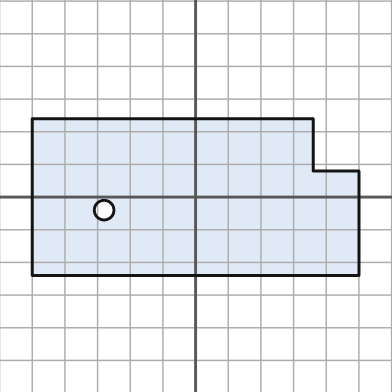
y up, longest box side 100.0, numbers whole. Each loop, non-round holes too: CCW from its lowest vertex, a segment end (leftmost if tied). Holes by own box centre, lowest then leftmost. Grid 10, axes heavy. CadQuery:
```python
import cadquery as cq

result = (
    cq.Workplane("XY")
    .moveTo(-50.0, -24.0)
    .lineTo(50.0, -24.0)
    .lineTo(50.0, 8.0)
    .lineTo(36.0, 8.0)
    .lineTo(36.0, 24.0)
    .lineTo(-50.0, 24.0)
    .close()
    .moveTo(-28.0, -4.0)
    .circle(3.0)
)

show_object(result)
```